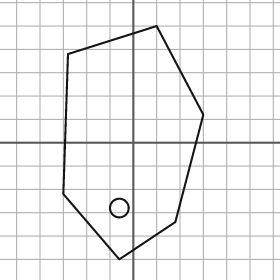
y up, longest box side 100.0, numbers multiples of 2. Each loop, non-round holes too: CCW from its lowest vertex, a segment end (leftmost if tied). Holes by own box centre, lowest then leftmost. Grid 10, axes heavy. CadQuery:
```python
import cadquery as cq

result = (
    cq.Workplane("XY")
    .moveTo(-6.0, -50.0)
    .lineTo(18.0, -34.0)
    .lineTo(30.0, 12.0)
    .lineTo(10.0, 50.0)
    .lineTo(-28.0, 38.0)
    .lineTo(-30.0, -22.0)
    .close()
    .moveTo(-6.0, -28.0)
    .circle(4.0)
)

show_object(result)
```